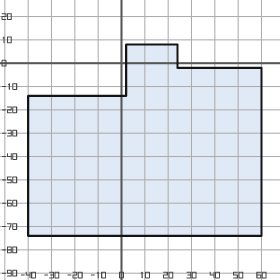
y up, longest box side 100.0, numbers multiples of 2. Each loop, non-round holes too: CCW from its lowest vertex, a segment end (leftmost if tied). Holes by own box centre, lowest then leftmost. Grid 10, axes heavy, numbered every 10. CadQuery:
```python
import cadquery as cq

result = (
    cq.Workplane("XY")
    .moveTo(-40.0, -74.0)
    .lineTo(60.0, -74.0)
    .lineTo(60.0, -2.0)
    .lineTo(24.0, -2.0)
    .lineTo(24.0, 8.0)
    .lineTo(2.0, 8.0)
    .lineTo(2.0, -14.0)
    .lineTo(-40.0, -14.0)
    .close()
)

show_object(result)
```